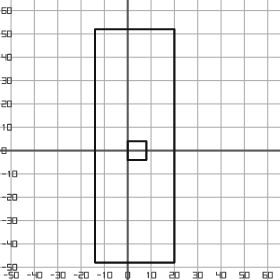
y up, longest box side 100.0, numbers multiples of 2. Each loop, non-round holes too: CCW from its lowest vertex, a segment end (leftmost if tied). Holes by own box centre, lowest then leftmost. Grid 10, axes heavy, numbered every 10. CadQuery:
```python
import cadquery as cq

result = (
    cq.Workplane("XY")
    .moveTo(-14.0, -48.0)
    .lineTo(20.0, -48.0)
    .lineTo(20.0, 52.0)
    .lineTo(-14.0, 52.0)
    .close()
    .moveTo(0.0, -4.0)
    .lineTo(8.0, -4.0)
    .lineTo(8.0, 4.0)
    .lineTo(0.0, 4.0)
    .close()
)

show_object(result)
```